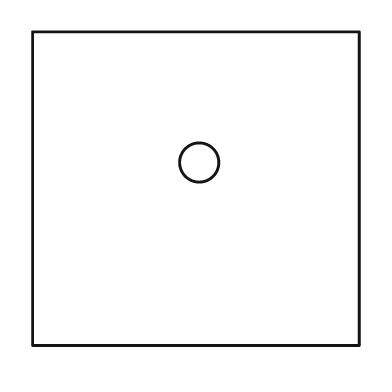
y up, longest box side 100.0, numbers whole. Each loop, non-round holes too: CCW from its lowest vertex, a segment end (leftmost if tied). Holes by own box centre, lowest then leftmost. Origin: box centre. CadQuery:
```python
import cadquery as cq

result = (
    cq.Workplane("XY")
    .moveTo(-50.0, -48.0)
    .lineTo(50.0, -48.0)
    .lineTo(50.0, 48.0)
    .lineTo(-50.0, 48.0)
    .close()
    .moveTo(1.0, 8.0)
    .circle(6.0)
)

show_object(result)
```